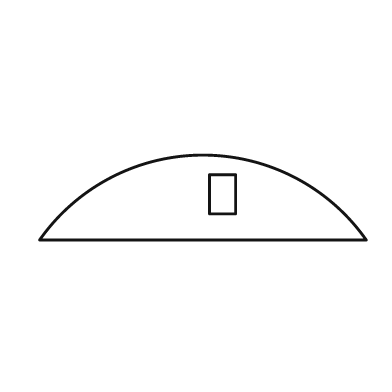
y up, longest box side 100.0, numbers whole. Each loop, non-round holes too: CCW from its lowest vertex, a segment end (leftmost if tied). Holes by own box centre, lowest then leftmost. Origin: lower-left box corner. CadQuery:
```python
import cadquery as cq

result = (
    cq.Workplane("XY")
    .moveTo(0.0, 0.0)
    .lineTo(100.0, 0.0)
    .threePointArc((50.0, 26.0), (0.0, 0.0))
    .close()
    .moveTo(52.0, 8.0)
    .lineTo(60.0, 8.0)
    .lineTo(60.0, 20.0)
    .lineTo(52.0, 20.0)
    .close()
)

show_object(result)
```